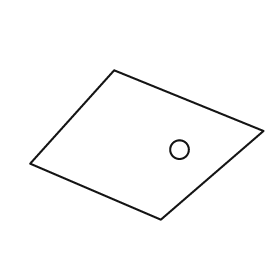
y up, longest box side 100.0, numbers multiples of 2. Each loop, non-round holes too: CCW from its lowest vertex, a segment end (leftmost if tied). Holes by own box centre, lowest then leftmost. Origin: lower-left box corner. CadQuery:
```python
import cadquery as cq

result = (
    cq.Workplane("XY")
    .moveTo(56.0, 0.0)
    .lineTo(100.0, 38.0)
    .lineTo(36.0, 64.0)
    .lineTo(0.0, 24.0)
    .close()
    .moveTo(64.0, 30.0)
    .circle(4.0)
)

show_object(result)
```